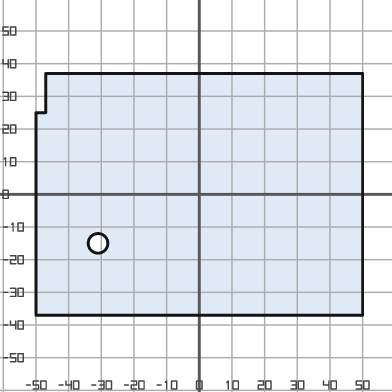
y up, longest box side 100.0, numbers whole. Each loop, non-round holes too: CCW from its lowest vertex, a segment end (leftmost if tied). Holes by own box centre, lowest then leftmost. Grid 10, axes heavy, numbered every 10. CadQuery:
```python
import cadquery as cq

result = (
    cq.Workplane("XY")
    .moveTo(-50.0, -37.0)
    .lineTo(50.0, -37.0)
    .lineTo(50.0, 37.0)
    .lineTo(-47.0, 37.0)
    .lineTo(-47.0, 25.0)
    .lineTo(-50.0, 25.0)
    .close()
    .moveTo(-31.0, -15.0)
    .circle(3.0)
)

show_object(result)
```